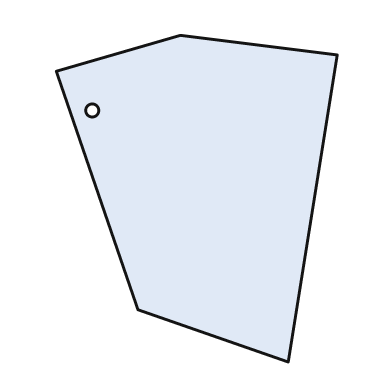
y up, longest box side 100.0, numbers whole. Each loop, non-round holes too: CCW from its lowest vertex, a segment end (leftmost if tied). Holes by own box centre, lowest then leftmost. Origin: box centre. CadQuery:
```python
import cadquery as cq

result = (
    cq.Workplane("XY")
    .moveTo(28.0, -50.0)
    .lineTo(43.0, 44.0)
    .lineTo(-5.0, 50.0)
    .lineTo(-43.0, 39.0)
    .lineTo(-18.0, -34.0)
    .close()
    .moveTo(-32.0, 27.0)
    .circle(2.0)
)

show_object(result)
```